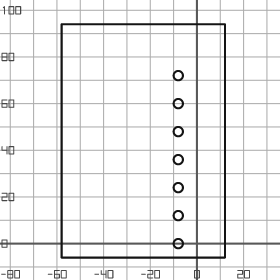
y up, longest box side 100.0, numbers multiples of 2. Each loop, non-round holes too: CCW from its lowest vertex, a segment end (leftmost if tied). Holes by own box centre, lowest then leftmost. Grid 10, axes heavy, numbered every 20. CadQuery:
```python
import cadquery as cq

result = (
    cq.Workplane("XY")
    .moveTo(-58.0, -6.0)
    .lineTo(12.0, -6.0)
    .lineTo(12.0, 94.0)
    .lineTo(-58.0, 94.0)
    .close()
    .moveTo(-8.0, 0.0)
    .circle(2.0)
    .moveTo(-8.0, 12.0)
    .circle(2.0)
    .moveTo(-8.0, 24.0)
    .circle(2.0)
    .moveTo(-8.0, 36.0)
    .circle(2.0)
    .moveTo(-8.0, 48.0)
    .circle(2.0)
    .moveTo(-8.0, 60.0)
    .circle(2.0)
    .moveTo(-8.0, 72.0)
    .circle(2.0)
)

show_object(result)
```